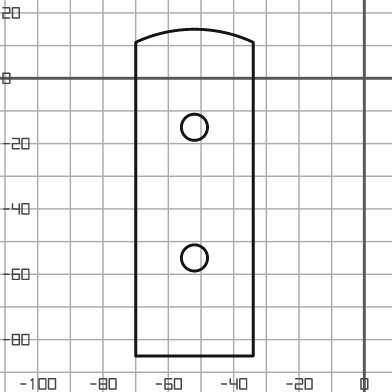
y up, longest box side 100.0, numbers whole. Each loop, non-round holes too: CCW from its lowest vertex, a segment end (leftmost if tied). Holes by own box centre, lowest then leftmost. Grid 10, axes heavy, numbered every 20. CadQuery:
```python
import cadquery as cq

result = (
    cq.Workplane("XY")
    .moveTo(-70.0, -85.0)
    .lineTo(-34.0, -85.0)
    .lineTo(-34.0, 11.0)
    .threePointArc((-52.0, 15.0), (-70.0, 11.0))
    .close()
    .moveTo(-52.0, -55.0)
    .circle(4.0)
    .moveTo(-52.0, -15.0)
    .circle(4.0)
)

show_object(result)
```